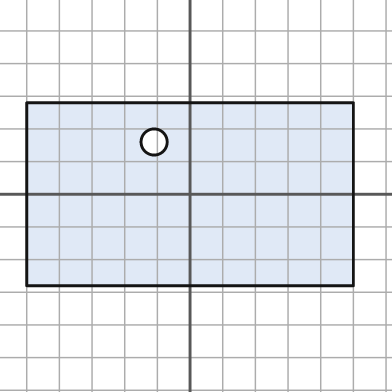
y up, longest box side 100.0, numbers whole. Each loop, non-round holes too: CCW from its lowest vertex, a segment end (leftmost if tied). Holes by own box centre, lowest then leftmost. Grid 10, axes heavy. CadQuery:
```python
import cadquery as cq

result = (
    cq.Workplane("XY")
    .moveTo(-50.0, -28.0)
    .lineTo(50.0, -28.0)
    .lineTo(50.0, 28.0)
    .lineTo(-50.0, 28.0)
    .close()
    .moveTo(-11.0, 16.0)
    .circle(4.0)
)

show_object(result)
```